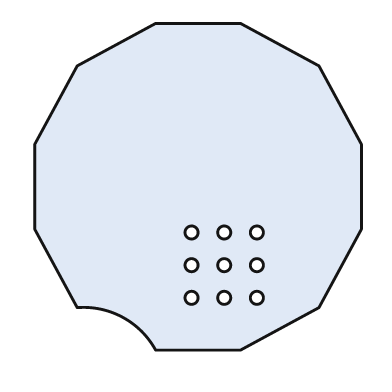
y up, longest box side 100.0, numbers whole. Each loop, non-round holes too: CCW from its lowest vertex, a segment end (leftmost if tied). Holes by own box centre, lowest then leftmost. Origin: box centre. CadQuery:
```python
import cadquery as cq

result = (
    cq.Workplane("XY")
    .moveTo(-13.0, -50.0)
    .lineTo(13.0, -50.0)
    .lineTo(37.0, -37.0)
    .lineTo(50.0, -13.0)
    .lineTo(50.0, 13.0)
    .lineTo(37.0, 37.0)
    .lineTo(13.0, 50.0)
    .lineTo(-13.0, 50.0)
    .lineTo(-37.0, 37.0)
    .lineTo(-50.0, 13.0)
    .lineTo(-50.0, -13.0)
    .lineTo(-37.0, -37.0)
    .threePointArc((-23.0, -40.0), (-13.0, -50.0))
    .close()
    .moveTo(-2.0, -34.0)
    .circle(2.0)
    .moveTo(8.0, -34.0)
    .circle(2.0)
    .moveTo(18.0, -34.0)
    .circle(2.0)
    .moveTo(-2.0, -24.0)
    .circle(2.0)
    .moveTo(8.0, -24.0)
    .circle(2.0)
    .moveTo(18.0, -24.0)
    .circle(2.0)
    .moveTo(-2.0, -14.0)
    .circle(2.0)
    .moveTo(8.0, -14.0)
    .circle(2.0)
    .moveTo(18.0, -14.0)
    .circle(2.0)
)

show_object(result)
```